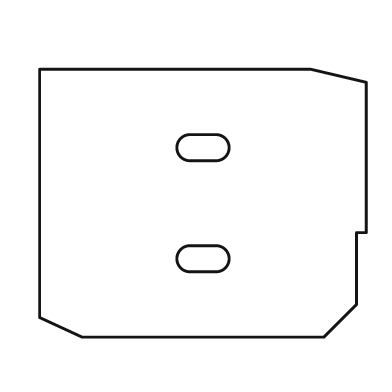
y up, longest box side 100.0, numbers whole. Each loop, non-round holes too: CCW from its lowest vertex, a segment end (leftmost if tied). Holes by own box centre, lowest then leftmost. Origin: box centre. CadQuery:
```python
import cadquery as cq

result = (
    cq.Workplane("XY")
    .moveTo(-37.0, -41.0)
    .lineTo(37.0, -41.0)
    .lineTo(47.0, -31.0)
    .lineTo(47.0, -9.0)
    .lineTo(50.0, -9.0)
    .lineTo(50.0, 37.0)
    .lineTo(33.0, 41.0)
    .lineTo(-50.0, 41.0)
    .lineTo(-50.0, -35.0)
    .close()
    .moveTo(-4.0, -21.0)
    .lineTo(4.0, -21.0)
    .threePointArc((8.0, -17.0), (4.0, -13.0))
    .lineTo(-4.0, -13.0)
    .threePointArc((-8.0, -17.0), (-4.0, -21.0))
    .close()
    .moveTo(-4.0, 13.0)
    .lineTo(4.0, 13.0)
    .threePointArc((8.0, 17.0), (4.0, 21.0))
    .lineTo(-4.0, 21.0)
    .threePointArc((-8.0, 17.0), (-4.0, 13.0))
    .close()
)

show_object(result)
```